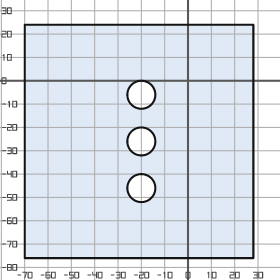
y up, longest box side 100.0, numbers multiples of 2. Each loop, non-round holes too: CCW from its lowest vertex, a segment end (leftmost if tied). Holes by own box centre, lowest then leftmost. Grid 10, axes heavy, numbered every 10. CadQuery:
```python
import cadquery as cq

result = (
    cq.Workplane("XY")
    .moveTo(-70.0, -76.0)
    .lineTo(28.0, -76.0)
    .lineTo(28.0, 24.0)
    .lineTo(-70.0, 24.0)
    .close()
    .moveTo(-20.0, -46.0)
    .circle(6.0)
    .moveTo(-20.0, -26.0)
    .circle(6.0)
    .moveTo(-20.0, -6.0)
    .circle(6.0)
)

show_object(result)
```